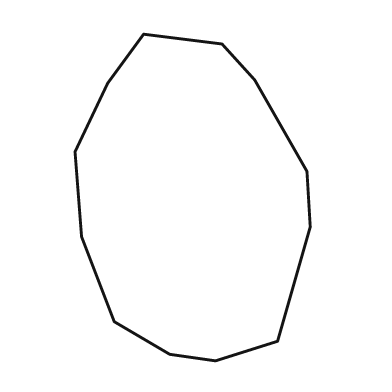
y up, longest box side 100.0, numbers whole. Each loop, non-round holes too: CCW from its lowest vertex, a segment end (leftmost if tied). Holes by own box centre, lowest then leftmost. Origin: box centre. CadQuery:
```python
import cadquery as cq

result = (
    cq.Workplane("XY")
    .moveTo(7.0, -50.0)
    .lineTo(26.0, -44.0)
    .lineTo(36.0, -9.0)
    .lineTo(35.0, 8.0)
    .lineTo(19.0, 36.0)
    .lineTo(9.0, 47.0)
    .lineTo(-15.0, 50.0)
    .lineTo(-26.0, 35.0)
    .lineTo(-36.0, 14.0)
    .lineTo(-34.0, -12.0)
    .lineTo(-24.0, -38.0)
    .lineTo(-7.0, -48.0)
    .close()
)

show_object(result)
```